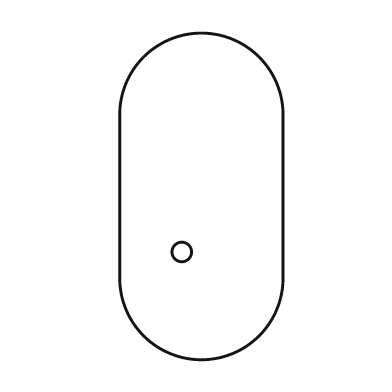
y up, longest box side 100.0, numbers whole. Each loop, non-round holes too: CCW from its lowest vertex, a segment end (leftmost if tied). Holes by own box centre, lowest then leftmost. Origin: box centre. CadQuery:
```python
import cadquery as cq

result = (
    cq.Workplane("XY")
    .moveTo(-25.0, -25.0)
    .threePointArc((0.0, -50.0), (25.0, -25.0))
    .lineTo(25.0, 25.0)
    .threePointArc((0.0, 50.0), (-25.0, 25.0))
    .close()
    .moveTo(-6.0, -17.0)
    .circle(3.0)
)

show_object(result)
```